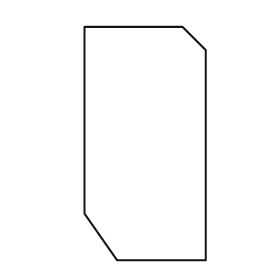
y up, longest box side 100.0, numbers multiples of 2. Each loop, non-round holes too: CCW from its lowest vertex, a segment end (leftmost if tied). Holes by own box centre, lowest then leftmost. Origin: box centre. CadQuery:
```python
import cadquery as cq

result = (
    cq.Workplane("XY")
    .moveTo(-12.0, -50.0)
    .lineTo(26.0, -50.0)
    .lineTo(26.0, 40.0)
    .lineTo(16.0, 50.0)
    .lineTo(-26.0, 50.0)
    .lineTo(-26.0, -30.0)
    .close()
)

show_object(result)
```